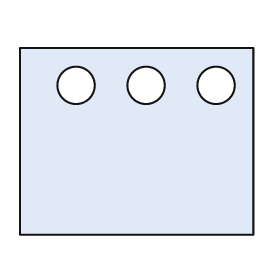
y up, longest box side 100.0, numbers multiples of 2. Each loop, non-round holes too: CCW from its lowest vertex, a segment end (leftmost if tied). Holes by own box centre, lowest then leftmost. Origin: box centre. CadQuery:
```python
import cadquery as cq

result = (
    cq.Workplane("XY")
    .moveTo(-50.0, -40.0)
    .lineTo(50.0, -40.0)
    .lineTo(50.0, 40.0)
    .lineTo(-50.0, 40.0)
    .close()
    .moveTo(-26.0, 24.0)
    .circle(8.0)
    .moveTo(4.0, 24.0)
    .circle(8.0)
    .moveTo(34.0, 24.0)
    .circle(8.0)
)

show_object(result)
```